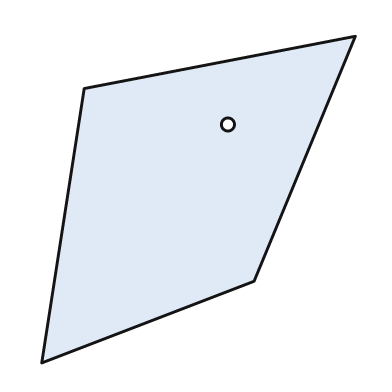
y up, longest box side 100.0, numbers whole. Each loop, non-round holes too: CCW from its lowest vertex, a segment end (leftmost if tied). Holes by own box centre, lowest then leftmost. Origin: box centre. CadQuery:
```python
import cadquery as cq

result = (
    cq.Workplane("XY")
    .moveTo(-48.0, -50.0)
    .lineTo(17.0, -25.0)
    .lineTo(48.0, 50.0)
    .lineTo(-35.0, 34.0)
    .close()
    .moveTo(9.0, 23.0)
    .circle(2.0)
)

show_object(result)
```